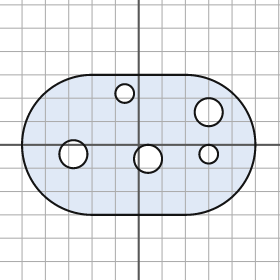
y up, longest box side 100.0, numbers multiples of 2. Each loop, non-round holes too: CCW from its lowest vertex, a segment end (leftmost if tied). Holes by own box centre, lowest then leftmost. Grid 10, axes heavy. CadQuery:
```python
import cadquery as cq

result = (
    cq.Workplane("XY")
    .moveTo(-20.0, -30.0)
    .lineTo(20.0, -30.0)
    .threePointArc((50.0, 0.0), (20.0, 30.0))
    .lineTo(-20.0, 30.0)
    .threePointArc((-50.0, 0.0), (-20.0, -30.0))
    .close()
    .moveTo(4.0, -6.0)
    .circle(6.0)
    .moveTo(-28.0, -4.0)
    .circle(6.0)
    .moveTo(30.0, -4.0)
    .circle(4.0)
    .moveTo(30.0, 14.0)
    .circle(6.0)
    .moveTo(-6.0, 22.0)
    .circle(4.0)
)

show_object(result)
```